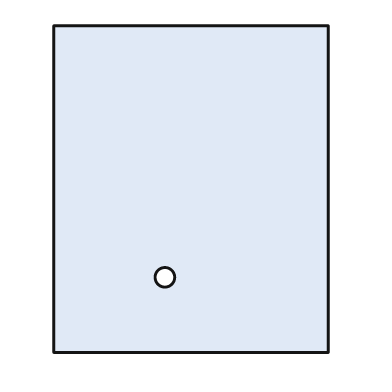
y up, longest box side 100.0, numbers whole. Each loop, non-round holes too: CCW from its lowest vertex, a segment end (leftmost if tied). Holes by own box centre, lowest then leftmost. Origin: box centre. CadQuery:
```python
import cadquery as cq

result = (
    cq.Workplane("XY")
    .moveTo(-42.0, -50.0)
    .lineTo(42.0, -50.0)
    .lineTo(42.0, 50.0)
    .lineTo(-42.0, 50.0)
    .close()
    .moveTo(-8.0, -27.0)
    .circle(3.0)
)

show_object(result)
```